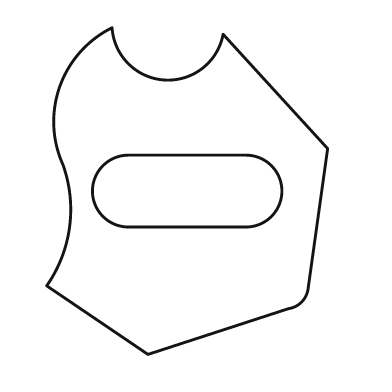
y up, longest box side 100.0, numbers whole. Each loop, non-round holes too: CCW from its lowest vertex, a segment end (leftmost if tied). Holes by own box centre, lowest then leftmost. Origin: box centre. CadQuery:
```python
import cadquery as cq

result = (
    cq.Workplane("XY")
    .moveTo(-12.0, -50.0)
    .lineTo(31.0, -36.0)
    .threePointArc((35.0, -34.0), (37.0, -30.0))
    .lineTo(43.0, 13.0)
    .lineTo(11.0, 48.0)
    .threePointArc((-7.0, 34.0), (-23.0, 50.0))
    .threePointArc((-39.0, 32.0), (-38.0, 8.0))
    .threePointArc((-36.0, -11.0), (-43.0, -29.0))
    .close()
    .moveTo(-18.0, -11.0)
    .lineTo(18.0, -11.0)
    .threePointArc((29.0, 0.0), (18.0, 11.0))
    .lineTo(-18.0, 11.0)
    .threePointArc((-29.0, 0.0), (-18.0, -11.0))
    .close()
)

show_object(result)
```